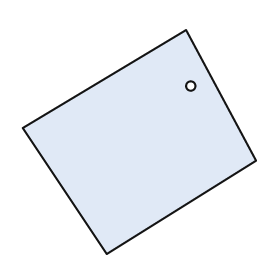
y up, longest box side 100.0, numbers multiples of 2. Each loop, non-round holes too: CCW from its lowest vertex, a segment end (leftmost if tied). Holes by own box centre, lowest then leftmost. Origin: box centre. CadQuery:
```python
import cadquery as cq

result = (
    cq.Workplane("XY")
    .moveTo(-14.0, -48.0)
    .lineTo(50.0, -8.0)
    .lineTo(20.0, 48.0)
    .lineTo(-50.0, 6.0)
    .close()
    .moveTo(22.0, 24.0)
    .circle(2.0)
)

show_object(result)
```